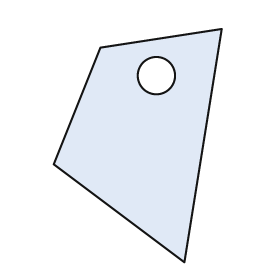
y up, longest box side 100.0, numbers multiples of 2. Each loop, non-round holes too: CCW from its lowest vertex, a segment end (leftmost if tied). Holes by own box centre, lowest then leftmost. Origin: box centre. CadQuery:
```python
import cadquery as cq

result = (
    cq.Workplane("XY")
    .moveTo(20.0, -50.0)
    .lineTo(36.0, 50.0)
    .lineTo(-16.0, 42.0)
    .lineTo(-36.0, -8.0)
    .close()
    .moveTo(8.0, 30.0)
    .circle(8.0)
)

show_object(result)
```